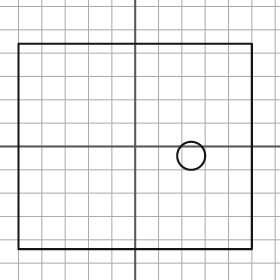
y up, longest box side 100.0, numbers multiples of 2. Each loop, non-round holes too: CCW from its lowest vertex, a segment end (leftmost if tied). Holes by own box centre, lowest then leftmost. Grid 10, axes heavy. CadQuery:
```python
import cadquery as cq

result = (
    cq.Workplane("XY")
    .moveTo(-50.0, -44.0)
    .lineTo(50.0, -44.0)
    .lineTo(50.0, 44.0)
    .lineTo(-50.0, 44.0)
    .close()
    .moveTo(24.0, -4.0)
    .circle(6.0)
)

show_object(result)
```